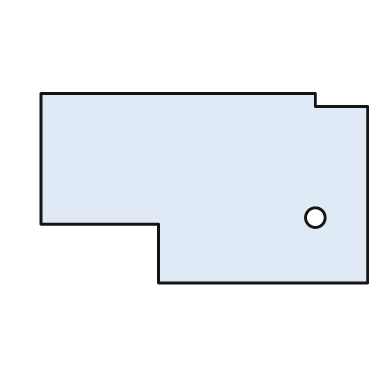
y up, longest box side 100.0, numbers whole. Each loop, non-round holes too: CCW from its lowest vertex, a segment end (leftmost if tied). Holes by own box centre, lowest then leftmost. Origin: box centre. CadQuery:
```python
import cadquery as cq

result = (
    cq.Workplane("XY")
    .moveTo(-14.0, -29.0)
    .lineTo(50.0, -29.0)
    .lineTo(50.0, 25.0)
    .lineTo(34.0, 25.0)
    .lineTo(34.0, 29.0)
    .lineTo(-50.0, 29.0)
    .lineTo(-50.0, -11.0)
    .lineTo(-14.0, -11.0)
    .close()
    .moveTo(34.0, -9.0)
    .circle(3.0)
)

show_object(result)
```